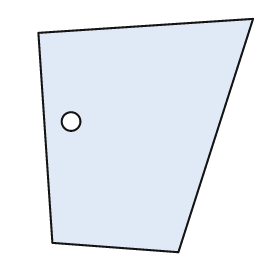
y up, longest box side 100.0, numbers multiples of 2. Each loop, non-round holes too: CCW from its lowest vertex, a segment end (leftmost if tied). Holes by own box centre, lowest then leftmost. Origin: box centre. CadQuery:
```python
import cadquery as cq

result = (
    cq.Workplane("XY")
    .moveTo(14.0, -50.0)
    .lineTo(46.0, 50.0)
    .lineTo(-46.0, 44.0)
    .lineTo(-40.0, -46.0)
    .close()
    .moveTo(-32.0, 6.0)
    .circle(4.0)
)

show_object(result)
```